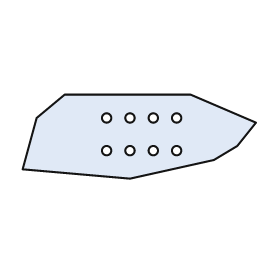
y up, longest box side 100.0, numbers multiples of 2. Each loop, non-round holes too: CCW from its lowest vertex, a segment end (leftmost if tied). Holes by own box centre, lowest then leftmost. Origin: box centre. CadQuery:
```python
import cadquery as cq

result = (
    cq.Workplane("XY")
    .moveTo(-4.0, -18.0)
    .lineTo(32.0, -10.0)
    .lineTo(42.0, -4.0)
    .lineTo(50.0, 6.0)
    .lineTo(22.0, 18.0)
    .lineTo(-32.0, 18.0)
    .lineTo(-44.0, 8.0)
    .lineTo(-50.0, -14.0)
    .close()
    .moveTo(-14.0, -6.0)
    .circle(2.0)
    .moveTo(-4.0, -6.0)
    .circle(2.0)
    .moveTo(6.0, -6.0)
    .circle(2.0)
    .moveTo(16.0, -6.0)
    .circle(2.0)
    .moveTo(-14.0, 8.0)
    .circle(2.0)
    .moveTo(-4.0, 8.0)
    .circle(2.0)
    .moveTo(6.0, 8.0)
    .circle(2.0)
    .moveTo(16.0, 8.0)
    .circle(2.0)
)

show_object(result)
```